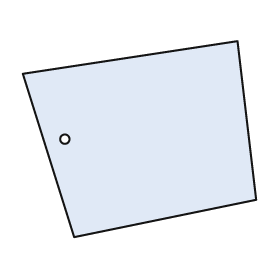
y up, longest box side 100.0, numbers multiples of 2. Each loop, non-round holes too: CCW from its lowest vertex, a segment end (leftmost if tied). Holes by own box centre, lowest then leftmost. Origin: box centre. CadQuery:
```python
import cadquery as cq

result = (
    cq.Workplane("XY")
    .moveTo(-28.0, -42.0)
    .lineTo(50.0, -26.0)
    .lineTo(42.0, 42.0)
    .lineTo(-50.0, 28.0)
    .close()
    .moveTo(-32.0, 0.0)
    .circle(2.0)
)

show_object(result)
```